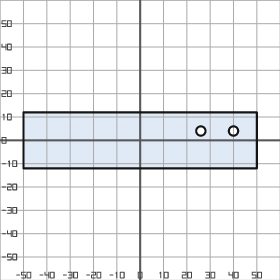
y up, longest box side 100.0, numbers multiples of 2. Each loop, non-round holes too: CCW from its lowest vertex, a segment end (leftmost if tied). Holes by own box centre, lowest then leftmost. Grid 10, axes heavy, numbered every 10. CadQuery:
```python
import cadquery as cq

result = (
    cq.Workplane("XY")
    .moveTo(-50.0, -12.0)
    .lineTo(50.0, -12.0)
    .lineTo(50.0, 12.0)
    .lineTo(-50.0, 12.0)
    .close()
    .moveTo(26.0, 4.0)
    .circle(2.0)
    .moveTo(40.0, 4.0)
    .circle(2.0)
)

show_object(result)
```